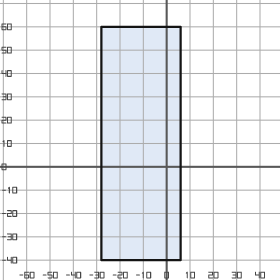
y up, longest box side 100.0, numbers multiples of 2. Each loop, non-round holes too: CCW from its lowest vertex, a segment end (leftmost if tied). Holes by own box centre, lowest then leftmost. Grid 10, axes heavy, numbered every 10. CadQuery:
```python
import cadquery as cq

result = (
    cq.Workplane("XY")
    .moveTo(-28.0, -40.0)
    .lineTo(6.0, -40.0)
    .lineTo(6.0, 60.0)
    .lineTo(-28.0, 60.0)
    .close()
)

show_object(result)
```